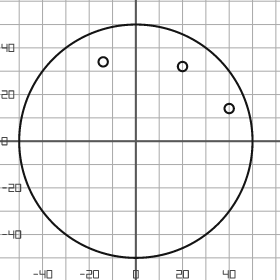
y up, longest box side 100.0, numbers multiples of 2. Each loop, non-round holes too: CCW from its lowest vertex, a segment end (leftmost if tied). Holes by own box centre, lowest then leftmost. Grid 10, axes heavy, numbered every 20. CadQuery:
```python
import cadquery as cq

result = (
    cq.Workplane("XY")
    .moveTo(0.0, 0.0)
    .circle(50.0)
    .moveTo(40.0, 14.0)
    .circle(2.0)
    .moveTo(20.0, 32.0)
    .circle(2.0)
    .moveTo(-14.0, 34.0)
    .circle(2.0)
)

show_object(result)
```